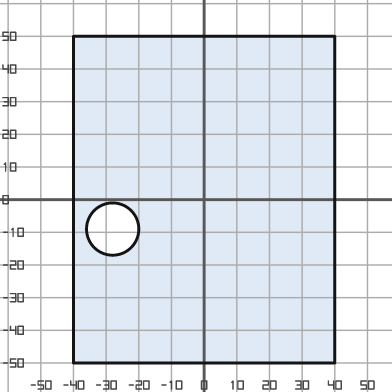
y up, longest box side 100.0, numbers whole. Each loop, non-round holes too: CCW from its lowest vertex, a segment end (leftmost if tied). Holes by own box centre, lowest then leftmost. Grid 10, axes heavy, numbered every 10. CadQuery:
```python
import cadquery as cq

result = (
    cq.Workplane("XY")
    .moveTo(-40.0, -50.0)
    .lineTo(40.0, -50.0)
    .lineTo(40.0, 50.0)
    .lineTo(-40.0, 50.0)
    .close()
    .moveTo(-28.0, -9.0)
    .circle(8.0)
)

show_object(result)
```